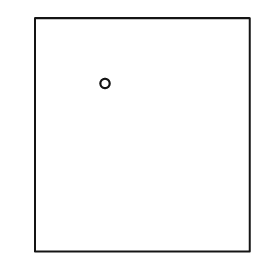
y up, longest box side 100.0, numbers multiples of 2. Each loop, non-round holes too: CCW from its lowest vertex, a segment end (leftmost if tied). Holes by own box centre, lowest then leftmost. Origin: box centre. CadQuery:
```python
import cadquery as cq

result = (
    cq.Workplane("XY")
    .moveTo(-46.0, -50.0)
    .lineTo(46.0, -50.0)
    .lineTo(46.0, 50.0)
    .lineTo(-46.0, 50.0)
    .close()
    .moveTo(-16.0, 22.0)
    .circle(2.0)
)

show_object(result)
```